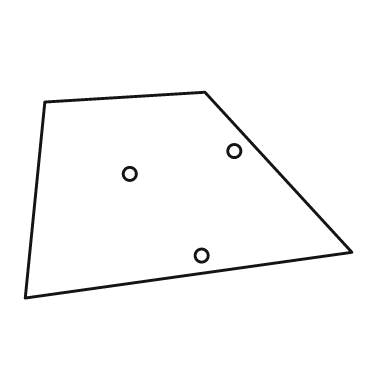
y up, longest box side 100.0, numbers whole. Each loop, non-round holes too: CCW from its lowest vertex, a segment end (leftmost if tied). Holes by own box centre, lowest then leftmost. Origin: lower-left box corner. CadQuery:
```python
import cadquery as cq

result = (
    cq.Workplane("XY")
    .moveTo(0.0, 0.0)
    .lineTo(100.0, 14.0)
    .lineTo(55.0, 63.0)
    .lineTo(6.0, 60.0)
    .close()
    .moveTo(54.0, 13.0)
    .circle(2.0)
    .moveTo(32.0, 38.0)
    .circle(2.0)
    .moveTo(64.0, 45.0)
    .circle(2.0)
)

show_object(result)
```